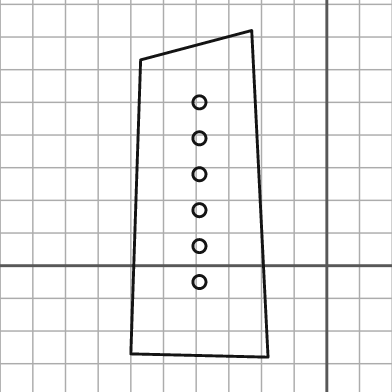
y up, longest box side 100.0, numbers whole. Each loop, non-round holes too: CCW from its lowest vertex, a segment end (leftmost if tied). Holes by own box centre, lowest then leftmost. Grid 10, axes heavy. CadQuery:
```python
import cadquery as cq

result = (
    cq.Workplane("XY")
    .moveTo(-18.0, -28.0)
    .lineTo(-23.0, 72.0)
    .lineTo(-57.0, 63.0)
    .lineTo(-60.0, -27.0)
    .close()
    .moveTo(-39.0, -5.0)
    .circle(2.0)
    .moveTo(-39.0, 6.0)
    .circle(2.0)
    .moveTo(-39.0, 17.0)
    .circle(2.0)
    .moveTo(-39.0, 28.0)
    .circle(2.0)
    .moveTo(-39.0, 39.0)
    .circle(2.0)
    .moveTo(-39.0, 50.0)
    .circle(2.0)
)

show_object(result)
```